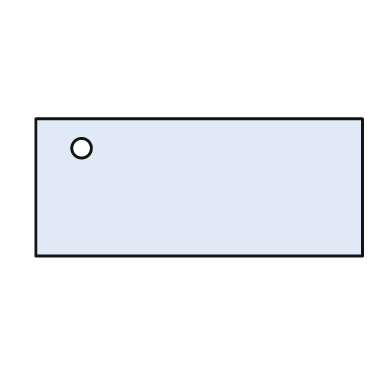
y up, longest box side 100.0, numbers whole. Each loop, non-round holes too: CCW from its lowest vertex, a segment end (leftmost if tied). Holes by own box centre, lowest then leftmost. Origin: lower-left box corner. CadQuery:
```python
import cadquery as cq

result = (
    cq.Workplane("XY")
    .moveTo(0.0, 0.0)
    .lineTo(100.0, 0.0)
    .lineTo(100.0, 42.0)
    .lineTo(0.0, 42.0)
    .close()
    .moveTo(14.0, 33.0)
    .circle(3.0)
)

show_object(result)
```